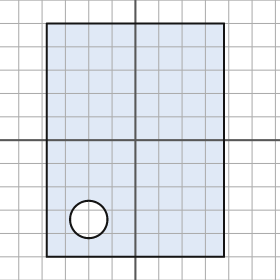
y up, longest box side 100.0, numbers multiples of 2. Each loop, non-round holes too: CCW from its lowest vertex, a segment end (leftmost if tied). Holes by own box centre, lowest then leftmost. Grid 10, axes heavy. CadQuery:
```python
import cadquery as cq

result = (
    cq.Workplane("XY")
    .moveTo(-38.0, -50.0)
    .lineTo(38.0, -50.0)
    .lineTo(38.0, 50.0)
    .lineTo(-38.0, 50.0)
    .close()
    .moveTo(-20.0, -34.0)
    .circle(8.0)
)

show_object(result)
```